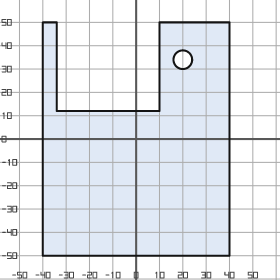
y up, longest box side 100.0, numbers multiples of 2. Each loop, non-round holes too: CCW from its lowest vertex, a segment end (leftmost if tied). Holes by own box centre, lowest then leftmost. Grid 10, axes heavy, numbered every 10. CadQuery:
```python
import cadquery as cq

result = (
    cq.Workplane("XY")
    .moveTo(-40.0, -50.0)
    .lineTo(40.0, -50.0)
    .lineTo(40.0, 50.0)
    .lineTo(10.0, 50.0)
    .lineTo(10.0, 12.0)
    .lineTo(-34.0, 12.0)
    .lineTo(-34.0, 50.0)
    .lineTo(-40.0, 50.0)
    .close()
    .moveTo(20.0, 34.0)
    .circle(4.0)
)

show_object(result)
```